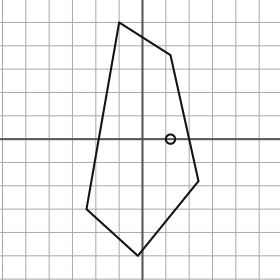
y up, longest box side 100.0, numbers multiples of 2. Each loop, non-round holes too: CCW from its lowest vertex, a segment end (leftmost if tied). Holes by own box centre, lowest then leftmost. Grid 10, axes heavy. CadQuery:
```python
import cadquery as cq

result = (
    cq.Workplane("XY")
    .moveTo(-2.0, -50.0)
    .lineTo(24.0, -18.0)
    .lineTo(12.0, 36.0)
    .lineTo(-10.0, 50.0)
    .lineTo(-24.0, -30.0)
    .close()
    .moveTo(12.0, 0.0)
    .circle(2.0)
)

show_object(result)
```